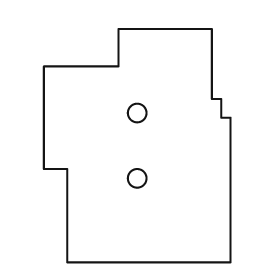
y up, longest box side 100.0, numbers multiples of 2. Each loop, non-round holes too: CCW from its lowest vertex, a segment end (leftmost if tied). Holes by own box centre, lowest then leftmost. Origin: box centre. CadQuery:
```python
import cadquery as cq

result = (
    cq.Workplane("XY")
    .moveTo(-30.0, -50.0)
    .lineTo(40.0, -50.0)
    .lineTo(40.0, 12.0)
    .lineTo(36.0, 12.0)
    .lineTo(36.0, 20.0)
    .lineTo(32.0, 20.0)
    .lineTo(32.0, 50.0)
    .lineTo(-8.0, 50.0)
    .lineTo(-8.0, 34.0)
    .lineTo(-40.0, 34.0)
    .lineTo(-40.0, -10.0)
    .lineTo(-30.0, -10.0)
    .close()
    .moveTo(0.0, -14.0)
    .circle(4.0)
    .moveTo(0.0, 14.0)
    .circle(4.0)
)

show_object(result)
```